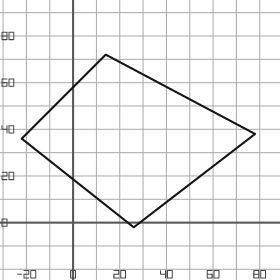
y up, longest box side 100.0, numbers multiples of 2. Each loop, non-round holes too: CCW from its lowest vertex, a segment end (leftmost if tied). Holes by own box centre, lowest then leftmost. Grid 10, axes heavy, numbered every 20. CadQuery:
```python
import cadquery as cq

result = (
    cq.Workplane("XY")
    .moveTo(26.0, -2.0)
    .lineTo(78.0, 38.0)
    .lineTo(14.0, 72.0)
    .lineTo(-22.0, 36.0)
    .close()
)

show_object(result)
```